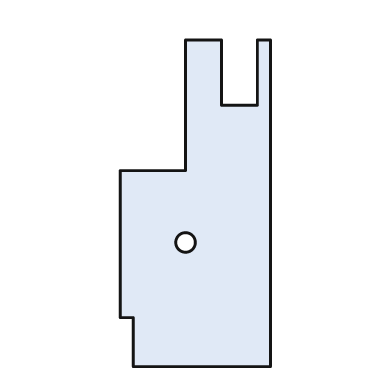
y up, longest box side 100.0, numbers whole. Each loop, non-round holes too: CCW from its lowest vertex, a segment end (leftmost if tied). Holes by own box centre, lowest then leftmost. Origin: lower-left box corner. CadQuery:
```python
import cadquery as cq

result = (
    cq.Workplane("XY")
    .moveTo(4.0, 0.0)
    .lineTo(46.0, 0.0)
    .lineTo(46.0, 100.0)
    .lineTo(42.0, 100.0)
    .lineTo(42.0, 80.0)
    .lineTo(31.0, 80.0)
    .lineTo(31.0, 100.0)
    .lineTo(20.0, 100.0)
    .lineTo(20.0, 60.0)
    .lineTo(0.0, 60.0)
    .lineTo(0.0, 15.0)
    .lineTo(4.0, 15.0)
    .close()
    .moveTo(20.0, 38.0)
    .circle(3.0)
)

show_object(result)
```